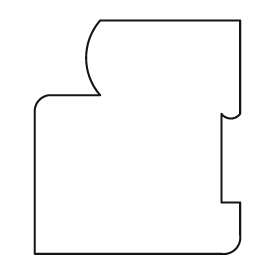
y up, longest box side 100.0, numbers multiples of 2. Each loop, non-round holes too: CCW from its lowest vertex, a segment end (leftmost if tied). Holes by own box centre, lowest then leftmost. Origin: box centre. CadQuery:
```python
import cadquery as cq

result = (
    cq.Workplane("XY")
    .moveTo(-44.0, -50.0)
    .lineTo(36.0, -50.0)
    .threePointArc((42.0, -48.0), (44.0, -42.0))
    .lineTo(44.0, -28.0)
    .lineTo(36.0, -28.0)
    .lineTo(36.0, 10.0)
    .threePointArc((40.0, 8.0), (44.0, 10.0))
    .lineTo(44.0, 50.0)
    .lineTo(-16.0, 50.0)
    .threePointArc((-22.0, 34.0), (-16.0, 18.0))
    .lineTo(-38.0, 18.0)
    .threePointArc((-42.0, 16.0), (-44.0, 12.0))
    .close()
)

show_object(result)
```